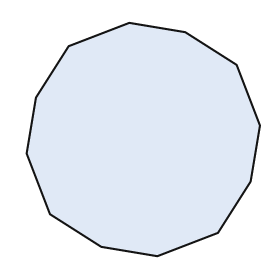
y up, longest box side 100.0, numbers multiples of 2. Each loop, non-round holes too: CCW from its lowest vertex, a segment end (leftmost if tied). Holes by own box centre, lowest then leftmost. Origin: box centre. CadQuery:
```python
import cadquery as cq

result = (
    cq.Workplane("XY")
    .moveTo(6.0, -50.0)
    .lineTo(32.0, -40.0)
    .lineTo(46.0, -18.0)
    .lineTo(50.0, 6.0)
    .lineTo(40.0, 32.0)
    .lineTo(18.0, 46.0)
    .lineTo(-6.0, 50.0)
    .lineTo(-32.0, 40.0)
    .lineTo(-46.0, 18.0)
    .lineTo(-50.0, -6.0)
    .lineTo(-40.0, -32.0)
    .lineTo(-18.0, -46.0)
    .close()
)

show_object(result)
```